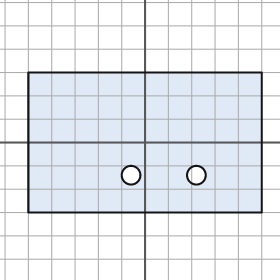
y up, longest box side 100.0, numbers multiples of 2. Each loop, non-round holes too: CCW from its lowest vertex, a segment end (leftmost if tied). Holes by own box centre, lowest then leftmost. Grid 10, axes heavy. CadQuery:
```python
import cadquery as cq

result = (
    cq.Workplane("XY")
    .moveTo(-50.0, -30.0)
    .lineTo(50.0, -30.0)
    .lineTo(50.0, 30.0)
    .lineTo(-50.0, 30.0)
    .close()
    .moveTo(-6.0, -14.0)
    .circle(4.0)
    .moveTo(22.0, -14.0)
    .circle(4.0)
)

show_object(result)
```